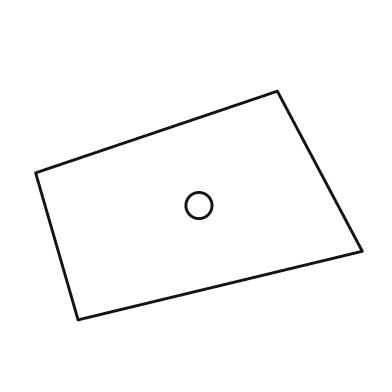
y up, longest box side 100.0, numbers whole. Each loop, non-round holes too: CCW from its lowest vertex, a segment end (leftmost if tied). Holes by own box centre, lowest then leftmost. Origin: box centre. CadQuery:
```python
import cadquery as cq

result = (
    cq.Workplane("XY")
    .moveTo(-37.0, -35.0)
    .lineTo(50.0, -14.0)
    .lineTo(24.0, 35.0)
    .lineTo(-50.0, 10.0)
    .close()
    .moveTo(0.0, 0.0)
    .circle(4.0)
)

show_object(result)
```